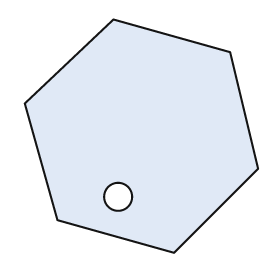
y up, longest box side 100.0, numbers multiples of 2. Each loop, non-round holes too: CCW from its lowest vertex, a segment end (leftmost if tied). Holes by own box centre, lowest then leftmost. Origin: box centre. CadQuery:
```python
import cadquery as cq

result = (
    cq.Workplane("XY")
    .moveTo(14.0, -50.0)
    .lineTo(50.0, -14.0)
    .lineTo(38.0, 36.0)
    .lineTo(-12.0, 50.0)
    .lineTo(-50.0, 14.0)
    .lineTo(-36.0, -36.0)
    .close()
    .moveTo(-10.0, -26.0)
    .circle(6.0)
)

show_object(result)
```